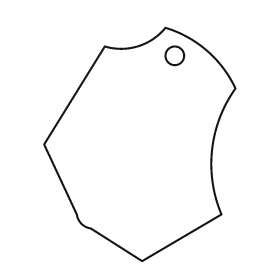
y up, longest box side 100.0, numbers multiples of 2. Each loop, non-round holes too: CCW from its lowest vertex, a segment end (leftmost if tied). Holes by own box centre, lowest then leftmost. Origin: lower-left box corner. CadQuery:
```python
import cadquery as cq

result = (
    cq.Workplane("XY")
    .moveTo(42.0, 0.0)
    .lineTo(76.0, 20.0)
    .threePointArc((72.0, 48.0), (82.0, 74.0))
    .threePointArc((70.0, 90.0), (52.0, 100.0))
    .threePointArc((40.0, 92.0), (26.0, 92.0))
    .lineTo(0.0, 50.0)
    .lineTo(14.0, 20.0)
    .threePointArc((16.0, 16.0), (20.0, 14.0))
    .close()
    .moveTo(56.0, 88.0)
    .circle(4.0)
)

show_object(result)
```